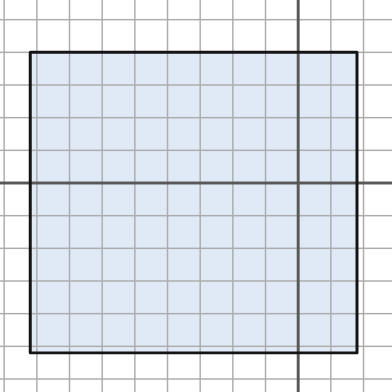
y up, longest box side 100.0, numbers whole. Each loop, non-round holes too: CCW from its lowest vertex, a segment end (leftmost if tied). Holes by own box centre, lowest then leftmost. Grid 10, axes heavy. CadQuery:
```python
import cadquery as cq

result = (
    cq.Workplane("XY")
    .moveTo(-82.0, -52.0)
    .lineTo(18.0, -52.0)
    .lineTo(18.0, 40.0)
    .lineTo(-82.0, 40.0)
    .close()
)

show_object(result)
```